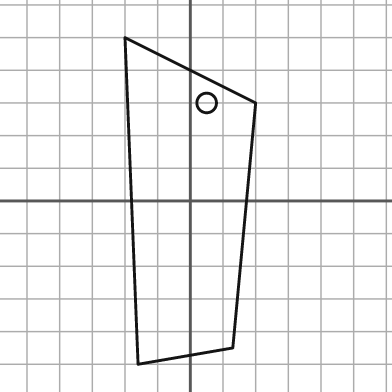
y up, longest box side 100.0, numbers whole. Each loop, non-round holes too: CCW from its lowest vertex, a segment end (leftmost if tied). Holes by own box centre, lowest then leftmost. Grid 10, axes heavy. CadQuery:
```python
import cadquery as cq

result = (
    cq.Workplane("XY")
    .moveTo(-16.0, -50.0)
    .lineTo(13.0, -45.0)
    .lineTo(20.0, 30.0)
    .lineTo(-20.0, 50.0)
    .close()
    .moveTo(5.0, 30.0)
    .circle(3.0)
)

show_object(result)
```